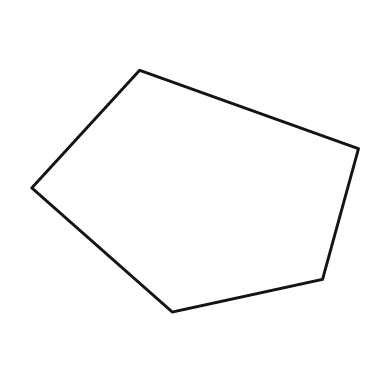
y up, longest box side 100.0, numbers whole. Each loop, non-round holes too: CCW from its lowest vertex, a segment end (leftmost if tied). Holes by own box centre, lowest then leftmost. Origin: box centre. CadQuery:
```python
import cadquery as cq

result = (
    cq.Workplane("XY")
    .moveTo(-7.0, -37.0)
    .lineTo(39.0, -27.0)
    .lineTo(50.0, 13.0)
    .lineTo(-17.0, 37.0)
    .lineTo(-50.0, 1.0)
    .close()
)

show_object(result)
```